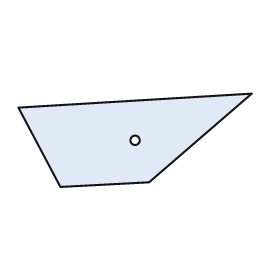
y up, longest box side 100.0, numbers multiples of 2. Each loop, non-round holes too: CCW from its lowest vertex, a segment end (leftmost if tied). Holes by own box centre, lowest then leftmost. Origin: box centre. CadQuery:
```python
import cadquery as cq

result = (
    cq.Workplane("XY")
    .moveTo(-32.0, -20.0)
    .lineTo(6.0, -18.0)
    .lineTo(50.0, 20.0)
    .lineTo(-50.0, 14.0)
    .close()
    .moveTo(0.0, 0.0)
    .circle(2.0)
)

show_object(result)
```